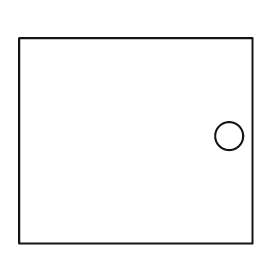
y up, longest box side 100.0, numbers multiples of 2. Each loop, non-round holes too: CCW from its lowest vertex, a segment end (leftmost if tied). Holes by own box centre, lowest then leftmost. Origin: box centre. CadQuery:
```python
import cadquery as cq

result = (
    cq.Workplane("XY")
    .moveTo(-50.0, -44.0)
    .lineTo(50.0, -44.0)
    .lineTo(50.0, 44.0)
    .lineTo(-50.0, 44.0)
    .close()
    .moveTo(40.0, 2.0)
    .circle(6.0)
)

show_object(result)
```